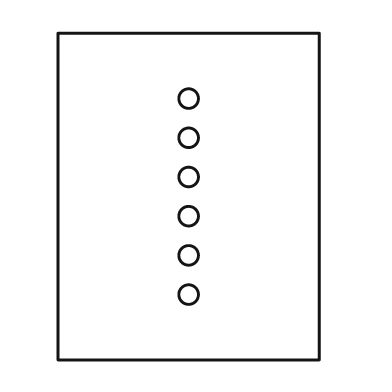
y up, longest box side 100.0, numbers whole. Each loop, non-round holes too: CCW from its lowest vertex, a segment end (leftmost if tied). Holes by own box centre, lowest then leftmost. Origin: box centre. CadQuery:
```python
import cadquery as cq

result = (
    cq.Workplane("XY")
    .moveTo(-40.0, -50.0)
    .lineTo(40.0, -50.0)
    .lineTo(40.0, 50.0)
    .lineTo(-40.0, 50.0)
    .close()
    .moveTo(0.0, -30.0)
    .circle(3.0)
    .moveTo(0.0, -18.0)
    .circle(3.0)
    .moveTo(0.0, -6.0)
    .circle(3.0)
    .moveTo(0.0, 6.0)
    .circle(3.0)
    .moveTo(0.0, 18.0)
    .circle(3.0)
    .moveTo(0.0, 30.0)
    .circle(3.0)
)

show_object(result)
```